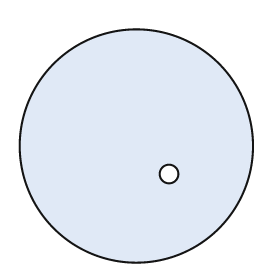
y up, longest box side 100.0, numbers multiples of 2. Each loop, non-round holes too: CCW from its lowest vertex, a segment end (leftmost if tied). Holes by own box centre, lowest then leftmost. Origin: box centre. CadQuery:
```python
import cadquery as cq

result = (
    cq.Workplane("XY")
    .moveTo(0.0, 0.0)
    .circle(50.0)
    .moveTo(14.0, -12.0)
    .circle(4.0)
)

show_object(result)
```